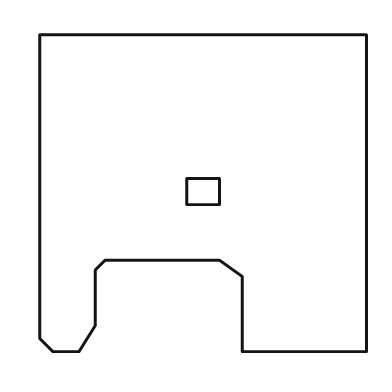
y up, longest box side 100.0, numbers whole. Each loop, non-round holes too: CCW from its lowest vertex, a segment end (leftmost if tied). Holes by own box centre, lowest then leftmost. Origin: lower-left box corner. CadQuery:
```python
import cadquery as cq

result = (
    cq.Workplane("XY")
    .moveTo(4.0, 0.0)
    .lineTo(12.0, 0.0)
    .lineTo(17.0, 8.0)
    .lineTo(17.0, 25.0)
    .lineTo(20.0, 28.0)
    .lineTo(55.0, 28.0)
    .lineTo(62.0, 23.0)
    .lineTo(62.0, 0.0)
    .lineTo(100.0, 0.0)
    .lineTo(100.0, 97.0)
    .lineTo(0.0, 97.0)
    .lineTo(0.0, 4.0)
    .close()
    .moveTo(45.0, 45.0)
    .lineTo(55.0, 45.0)
    .lineTo(55.0, 53.0)
    .lineTo(45.0, 53.0)
    .close()
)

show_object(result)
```